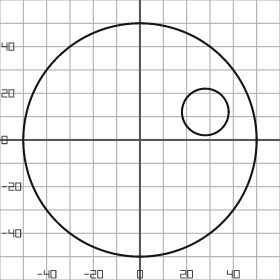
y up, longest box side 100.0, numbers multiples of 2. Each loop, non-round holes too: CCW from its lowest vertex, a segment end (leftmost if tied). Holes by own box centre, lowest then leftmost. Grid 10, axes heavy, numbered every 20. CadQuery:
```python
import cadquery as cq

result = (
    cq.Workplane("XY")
    .moveTo(0.0, 0.0)
    .circle(50.0)
    .moveTo(28.0, 12.0)
    .circle(10.0)
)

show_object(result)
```